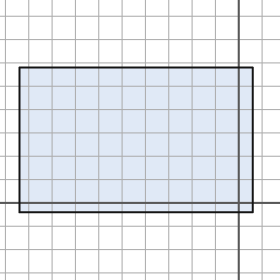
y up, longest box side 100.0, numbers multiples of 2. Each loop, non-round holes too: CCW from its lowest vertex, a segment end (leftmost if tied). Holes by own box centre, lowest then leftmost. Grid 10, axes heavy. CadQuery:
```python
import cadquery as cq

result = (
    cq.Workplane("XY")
    .moveTo(-94.0, -4.0)
    .lineTo(6.0, -4.0)
    .lineTo(6.0, 58.0)
    .lineTo(-94.0, 58.0)
    .close()
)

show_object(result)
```